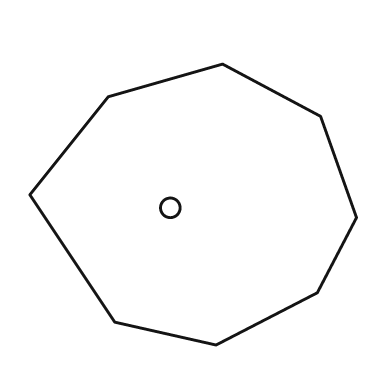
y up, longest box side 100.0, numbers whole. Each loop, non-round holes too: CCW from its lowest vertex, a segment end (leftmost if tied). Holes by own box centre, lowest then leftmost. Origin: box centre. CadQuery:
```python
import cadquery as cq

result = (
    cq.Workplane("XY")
    .moveTo(7.0, -43.0)
    .lineTo(38.0, -27.0)
    .lineTo(50.0, -4.0)
    .lineTo(39.0, 27.0)
    .lineTo(9.0, 43.0)
    .lineTo(-26.0, 33.0)
    .lineTo(-50.0, 3.0)
    .lineTo(-24.0, -36.0)
    .close()
    .moveTo(-7.0, -1.0)
    .circle(3.0)
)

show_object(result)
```